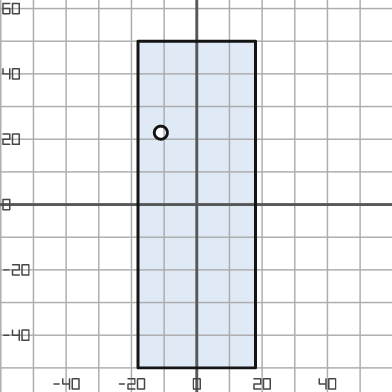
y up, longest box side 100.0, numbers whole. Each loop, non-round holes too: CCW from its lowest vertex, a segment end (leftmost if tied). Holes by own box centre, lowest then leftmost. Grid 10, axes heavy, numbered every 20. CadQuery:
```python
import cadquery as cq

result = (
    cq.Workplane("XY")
    .moveTo(-18.0, -50.0)
    .lineTo(18.0, -50.0)
    .lineTo(18.0, 50.0)
    .lineTo(-18.0, 50.0)
    .close()
    .moveTo(-11.0, 22.0)
    .circle(2.0)
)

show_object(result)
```